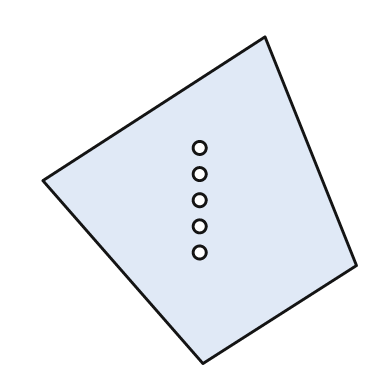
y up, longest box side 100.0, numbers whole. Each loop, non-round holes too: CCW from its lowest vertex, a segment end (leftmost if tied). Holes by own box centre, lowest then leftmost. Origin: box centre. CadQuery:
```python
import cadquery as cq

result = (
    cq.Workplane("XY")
    .moveTo(1.0, -50.0)
    .lineTo(48.0, -20.0)
    .lineTo(20.0, 50.0)
    .lineTo(-48.0, 6.0)
    .close()
    .moveTo(0.0, -16.0)
    .circle(2.0)
    .moveTo(0.0, -8.0)
    .circle(2.0)
    .moveTo(0.0, 0.0)
    .circle(2.0)
    .moveTo(0.0, 8.0)
    .circle(2.0)
    .moveTo(0.0, 16.0)
    .circle(2.0)
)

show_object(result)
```